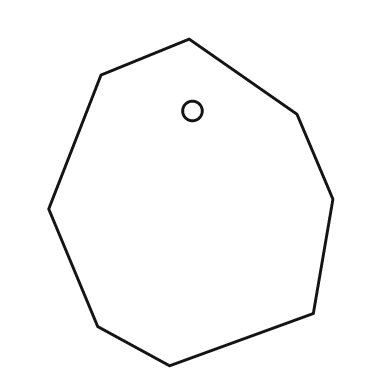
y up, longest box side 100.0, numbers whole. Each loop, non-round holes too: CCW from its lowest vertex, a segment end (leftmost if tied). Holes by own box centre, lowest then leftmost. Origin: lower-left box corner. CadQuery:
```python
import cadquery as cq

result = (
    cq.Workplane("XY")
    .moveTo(37.0, 0.0)
    .lineTo(81.0, 16.0)
    .lineTo(87.0, 51.0)
    .lineTo(76.0, 77.0)
    .lineTo(43.0, 100.0)
    .lineTo(16.0, 89.0)
    .lineTo(0.0, 48.0)
    .lineTo(15.0, 12.0)
    .close()
    .moveTo(44.0, 78.0)
    .circle(3.0)
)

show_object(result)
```